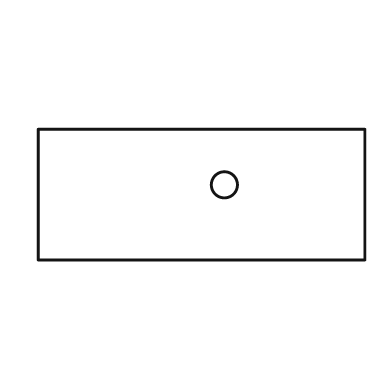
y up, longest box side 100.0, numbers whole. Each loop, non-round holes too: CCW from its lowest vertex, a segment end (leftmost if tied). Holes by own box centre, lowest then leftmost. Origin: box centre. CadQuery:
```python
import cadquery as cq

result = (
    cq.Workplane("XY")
    .moveTo(-50.0, -20.0)
    .lineTo(50.0, -20.0)
    .lineTo(50.0, 20.0)
    .lineTo(-50.0, 20.0)
    .close()
    .moveTo(7.0, 3.0)
    .circle(4.0)
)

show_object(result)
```